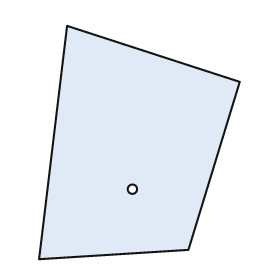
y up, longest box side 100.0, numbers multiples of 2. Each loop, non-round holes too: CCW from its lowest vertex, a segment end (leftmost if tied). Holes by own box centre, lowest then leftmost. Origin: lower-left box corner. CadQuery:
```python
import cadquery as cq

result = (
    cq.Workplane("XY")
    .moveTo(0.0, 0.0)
    .lineTo(64.0, 4.0)
    .lineTo(86.0, 76.0)
    .lineTo(12.0, 100.0)
    .close()
    .moveTo(40.0, 30.0)
    .circle(2.0)
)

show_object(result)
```